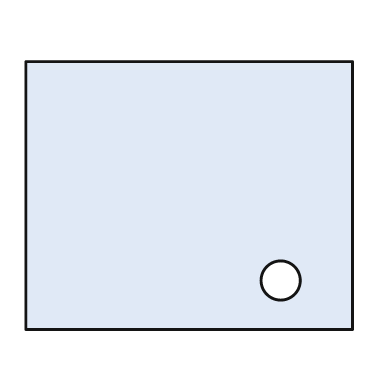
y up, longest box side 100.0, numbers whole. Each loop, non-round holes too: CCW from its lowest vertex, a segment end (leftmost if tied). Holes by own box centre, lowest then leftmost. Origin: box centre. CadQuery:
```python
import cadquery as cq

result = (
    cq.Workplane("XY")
    .moveTo(-50.0, -41.0)
    .lineTo(50.0, -41.0)
    .lineTo(50.0, 41.0)
    .lineTo(-50.0, 41.0)
    .close()
    .moveTo(28.0, -26.0)
    .circle(6.0)
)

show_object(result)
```